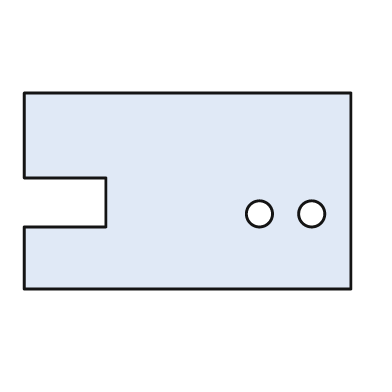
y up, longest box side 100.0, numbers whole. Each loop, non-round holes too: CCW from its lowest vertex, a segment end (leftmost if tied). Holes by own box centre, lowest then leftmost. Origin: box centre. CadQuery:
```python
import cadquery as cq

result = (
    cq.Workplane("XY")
    .moveTo(-50.0, -30.0)
    .lineTo(50.0, -30.0)
    .lineTo(50.0, 30.0)
    .lineTo(-50.0, 30.0)
    .lineTo(-50.0, 4.0)
    .lineTo(-25.0, 4.0)
    .lineTo(-25.0, -11.0)
    .lineTo(-50.0, -11.0)
    .close()
    .moveTo(22.0, -7.0)
    .circle(4.0)
    .moveTo(38.0, -7.0)
    .circle(4.0)
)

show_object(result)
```